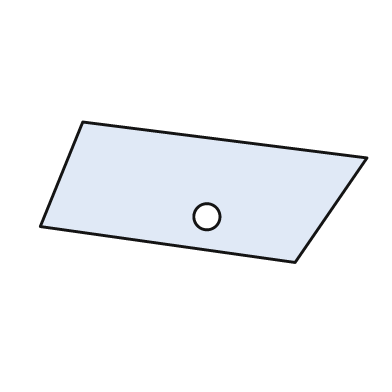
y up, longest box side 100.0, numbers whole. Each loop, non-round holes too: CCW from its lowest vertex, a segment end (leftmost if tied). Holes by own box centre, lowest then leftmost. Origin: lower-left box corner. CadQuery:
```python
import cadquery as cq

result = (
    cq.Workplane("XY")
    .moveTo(78.0, 0.0)
    .lineTo(100.0, 32.0)
    .lineTo(13.0, 43.0)
    .lineTo(0.0, 11.0)
    .close()
    .moveTo(51.0, 14.0)
    .circle(4.0)
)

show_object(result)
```